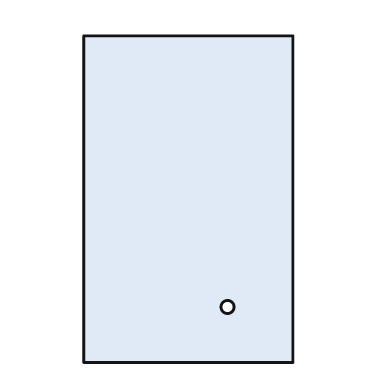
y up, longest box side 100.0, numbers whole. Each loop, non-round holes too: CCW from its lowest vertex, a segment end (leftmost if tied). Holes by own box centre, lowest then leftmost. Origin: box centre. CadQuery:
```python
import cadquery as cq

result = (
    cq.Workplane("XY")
    .moveTo(-32.0, -50.0)
    .lineTo(32.0, -50.0)
    .lineTo(32.0, 50.0)
    .lineTo(-32.0, 50.0)
    .close()
    .moveTo(12.0, -33.0)
    .circle(2.0)
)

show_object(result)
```